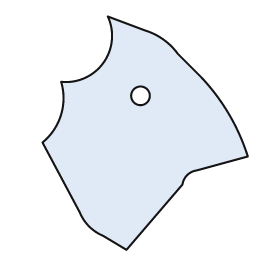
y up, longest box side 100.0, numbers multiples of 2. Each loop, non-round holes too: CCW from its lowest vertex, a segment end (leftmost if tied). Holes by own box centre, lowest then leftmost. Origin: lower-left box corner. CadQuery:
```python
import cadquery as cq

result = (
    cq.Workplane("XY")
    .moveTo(36.0, 0.0)
    .lineTo(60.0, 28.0)
    .threePointArc((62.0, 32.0), (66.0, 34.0))
    .lineTo(88.0, 40.0)
    .threePointArc((80.0, 58.0), (68.0, 74.0))
    .lineTo(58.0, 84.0)
    .threePointArc((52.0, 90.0), (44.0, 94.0))
    .lineTo(28.0, 100.0)
    .threePointArc((26.0, 80.0), (8.0, 72.0))
    .threePointArc((8.0, 58.0), (0.0, 46.0))
    .lineTo(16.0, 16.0)
    .threePointArc((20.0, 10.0), (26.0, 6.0))
    .close()
    .moveTo(42.0, 66.0)
    .circle(4.0)
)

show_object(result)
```